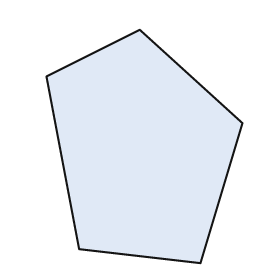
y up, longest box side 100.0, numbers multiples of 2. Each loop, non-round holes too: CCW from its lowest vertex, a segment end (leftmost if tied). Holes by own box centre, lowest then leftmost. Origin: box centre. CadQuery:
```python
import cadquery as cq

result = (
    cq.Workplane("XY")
    .moveTo(24.0, -50.0)
    .lineTo(42.0, 10.0)
    .lineTo(-2.0, 50.0)
    .lineTo(-42.0, 30.0)
    .lineTo(-28.0, -44.0)
    .close()
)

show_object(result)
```